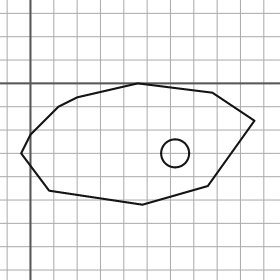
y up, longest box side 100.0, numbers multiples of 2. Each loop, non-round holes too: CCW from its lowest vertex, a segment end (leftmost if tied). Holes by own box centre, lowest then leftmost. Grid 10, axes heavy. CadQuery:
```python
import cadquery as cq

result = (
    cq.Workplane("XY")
    .moveTo(48.0, -52.0)
    .lineTo(76.0, -44.0)
    .lineTo(96.0, -16.0)
    .lineTo(78.0, -4.0)
    .lineTo(46.0, 0.0)
    .lineTo(20.0, -6.0)
    .lineTo(12.0, -10.0)
    .lineTo(0.0, -22.0)
    .lineTo(-4.0, -30.0)
    .lineTo(8.0, -46.0)
    .close()
    .moveTo(62.0, -30.0)
    .circle(6.0)
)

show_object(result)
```